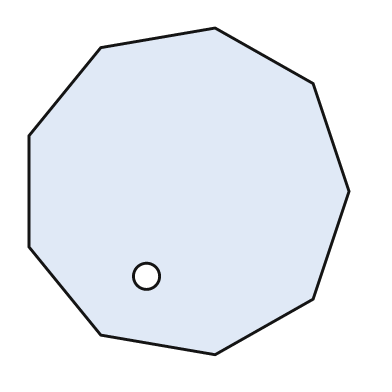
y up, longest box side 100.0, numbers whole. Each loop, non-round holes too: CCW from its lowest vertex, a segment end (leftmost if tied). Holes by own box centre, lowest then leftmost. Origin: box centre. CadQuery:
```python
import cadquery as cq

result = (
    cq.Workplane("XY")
    .moveTo(8.0, -50.0)
    .lineTo(38.0, -33.0)
    .lineTo(49.0, 0.0)
    .lineTo(38.0, 33.0)
    .lineTo(8.0, 50.0)
    .lineTo(-27.0, 44.0)
    .lineTo(-49.0, 17.0)
    .lineTo(-49.0, -17.0)
    .lineTo(-27.0, -44.0)
    .close()
    .moveTo(-13.0, -26.0)
    .circle(4.0)
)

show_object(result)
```